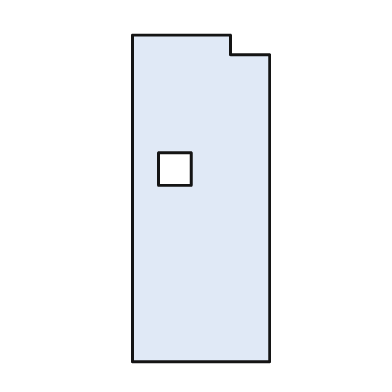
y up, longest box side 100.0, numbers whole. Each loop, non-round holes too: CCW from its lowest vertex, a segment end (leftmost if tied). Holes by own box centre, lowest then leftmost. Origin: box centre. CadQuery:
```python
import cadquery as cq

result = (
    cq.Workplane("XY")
    .moveTo(-21.0, -50.0)
    .lineTo(21.0, -50.0)
    .lineTo(21.0, 44.0)
    .lineTo(9.0, 44.0)
    .lineTo(9.0, 50.0)
    .lineTo(-21.0, 50.0)
    .close()
    .moveTo(-13.0, 4.0)
    .lineTo(-3.0, 4.0)
    .lineTo(-3.0, 14.0)
    .lineTo(-13.0, 14.0)
    .close()
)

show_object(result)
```